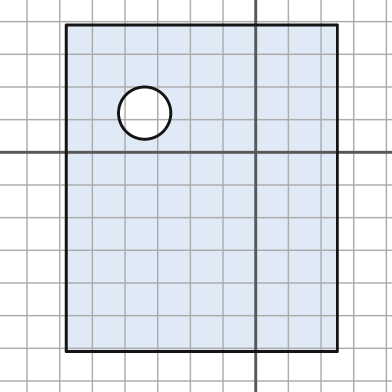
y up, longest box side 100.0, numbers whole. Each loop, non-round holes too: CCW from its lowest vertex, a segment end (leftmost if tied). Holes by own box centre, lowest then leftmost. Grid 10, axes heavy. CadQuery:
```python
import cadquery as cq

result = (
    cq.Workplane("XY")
    .moveTo(-58.0, -61.0)
    .lineTo(25.0, -61.0)
    .lineTo(25.0, 39.0)
    .lineTo(-58.0, 39.0)
    .close()
    .moveTo(-34.0, 12.0)
    .circle(8.0)
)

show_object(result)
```